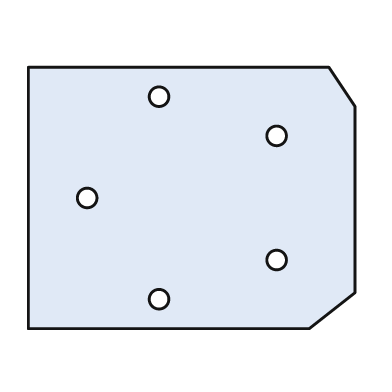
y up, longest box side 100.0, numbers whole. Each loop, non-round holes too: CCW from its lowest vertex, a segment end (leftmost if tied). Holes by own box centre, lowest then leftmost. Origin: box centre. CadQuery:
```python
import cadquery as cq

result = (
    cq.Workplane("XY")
    .moveTo(-50.0, -40.0)
    .lineTo(36.0, -40.0)
    .lineTo(50.0, -29.0)
    .lineTo(50.0, 28.0)
    .lineTo(42.0, 40.0)
    .lineTo(-50.0, 40.0)
    .close()
    .moveTo(-10.0, -31.0)
    .circle(3.0)
    .moveTo(26.0, -19.0)
    .circle(3.0)
    .moveTo(-32.0, 0.0)
    .circle(3.0)
    .moveTo(26.0, 19.0)
    .circle(3.0)
    .moveTo(-10.0, 31.0)
    .circle(3.0)
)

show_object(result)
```